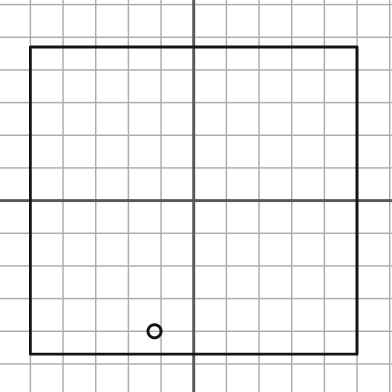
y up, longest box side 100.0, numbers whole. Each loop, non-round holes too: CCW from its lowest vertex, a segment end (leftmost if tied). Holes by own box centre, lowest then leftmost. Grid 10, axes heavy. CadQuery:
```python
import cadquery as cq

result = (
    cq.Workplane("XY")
    .moveTo(-50.0, -47.0)
    .lineTo(50.0, -47.0)
    .lineTo(50.0, 47.0)
    .lineTo(-50.0, 47.0)
    .close()
    .moveTo(-12.0, -40.0)
    .circle(2.0)
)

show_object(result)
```